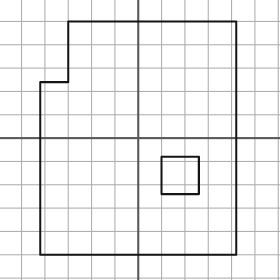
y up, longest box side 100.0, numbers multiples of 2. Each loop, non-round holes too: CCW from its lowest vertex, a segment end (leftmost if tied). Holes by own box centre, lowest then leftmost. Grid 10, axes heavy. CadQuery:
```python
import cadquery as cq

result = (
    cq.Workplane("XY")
    .moveTo(-42.0, -50.0)
    .lineTo(42.0, -50.0)
    .lineTo(42.0, 50.0)
    .lineTo(-30.0, 50.0)
    .lineTo(-30.0, 24.0)
    .lineTo(-42.0, 24.0)
    .close()
    .moveTo(10.0, -24.0)
    .lineTo(26.0, -24.0)
    .lineTo(26.0, -8.0)
    .lineTo(10.0, -8.0)
    .close()
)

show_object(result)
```